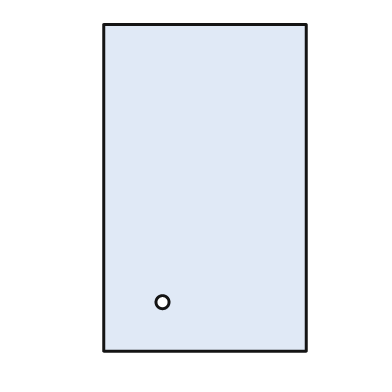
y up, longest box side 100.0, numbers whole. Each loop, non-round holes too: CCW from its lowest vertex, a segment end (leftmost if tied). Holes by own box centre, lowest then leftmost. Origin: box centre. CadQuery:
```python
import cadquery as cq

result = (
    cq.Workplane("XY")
    .moveTo(-31.0, -50.0)
    .lineTo(31.0, -50.0)
    .lineTo(31.0, 50.0)
    .lineTo(-31.0, 50.0)
    .close()
    .moveTo(-13.0, -35.0)
    .circle(2.0)
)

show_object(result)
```